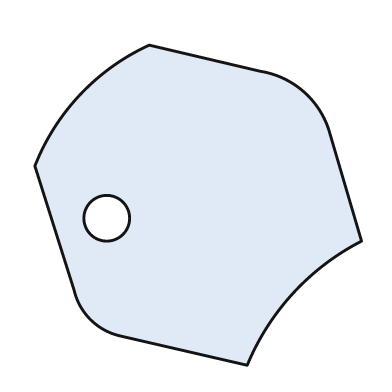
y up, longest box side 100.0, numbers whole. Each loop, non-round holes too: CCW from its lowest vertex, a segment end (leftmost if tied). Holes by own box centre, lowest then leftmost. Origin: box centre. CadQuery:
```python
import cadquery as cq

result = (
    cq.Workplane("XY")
    .moveTo(15.0, -49.0)
    .threePointArc((29.0, -27.0), (50.0, -11.0))
    .lineTo(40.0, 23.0)
    .threePointArc((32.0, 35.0), (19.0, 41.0))
    .lineTo(-15.0, 49.0)
    .threePointArc((-36.0, 34.0), (-50.0, 12.0))
    .lineTo(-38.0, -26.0)
    .threePointArc((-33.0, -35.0), (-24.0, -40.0))
    .close()
    .moveTo(-28.0, -4.0)
    .circle(7.0)
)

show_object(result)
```